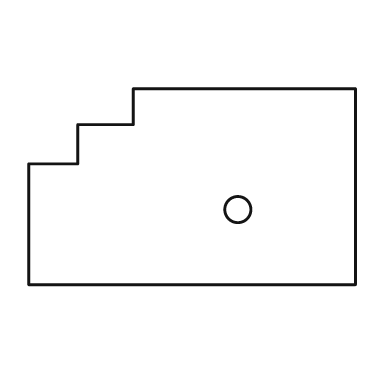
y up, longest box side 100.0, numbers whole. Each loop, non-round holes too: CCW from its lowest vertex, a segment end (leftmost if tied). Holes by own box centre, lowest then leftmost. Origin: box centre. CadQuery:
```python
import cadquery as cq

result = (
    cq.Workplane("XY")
    .moveTo(-50.0, -30.0)
    .lineTo(50.0, -30.0)
    .lineTo(50.0, 30.0)
    .lineTo(-18.0, 30.0)
    .lineTo(-18.0, 19.0)
    .lineTo(-35.0, 19.0)
    .lineTo(-35.0, 7.0)
    .lineTo(-50.0, 7.0)
    .close()
    .moveTo(14.0, -7.0)
    .circle(4.0)
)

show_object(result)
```